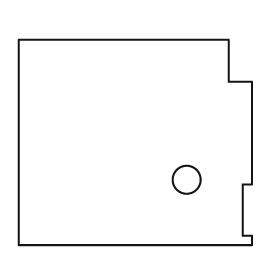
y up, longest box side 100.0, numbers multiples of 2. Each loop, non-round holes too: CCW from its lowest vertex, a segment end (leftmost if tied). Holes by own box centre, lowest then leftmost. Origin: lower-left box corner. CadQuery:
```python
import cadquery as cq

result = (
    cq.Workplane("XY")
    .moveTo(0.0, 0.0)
    .lineTo(100.0, 0.0)
    .lineTo(100.0, 4.0)
    .lineTo(96.0, 4.0)
    .lineTo(96.0, 26.0)
    .lineTo(100.0, 26.0)
    .lineTo(100.0, 70.0)
    .lineTo(90.0, 70.0)
    .lineTo(90.0, 88.0)
    .lineTo(0.0, 88.0)
    .close()
    .moveTo(72.0, 28.0)
    .circle(6.0)
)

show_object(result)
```